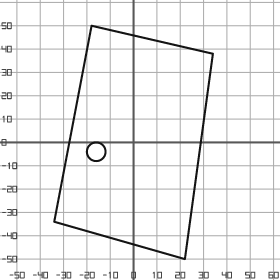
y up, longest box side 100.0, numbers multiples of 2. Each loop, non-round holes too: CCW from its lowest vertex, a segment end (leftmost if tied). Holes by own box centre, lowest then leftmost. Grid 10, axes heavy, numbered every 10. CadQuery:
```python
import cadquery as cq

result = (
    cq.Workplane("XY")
    .moveTo(22.0, -50.0)
    .lineTo(34.0, 38.0)
    .lineTo(-18.0, 50.0)
    .lineTo(-34.0, -34.0)
    .close()
    .moveTo(-16.0, -4.0)
    .circle(4.0)
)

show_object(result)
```